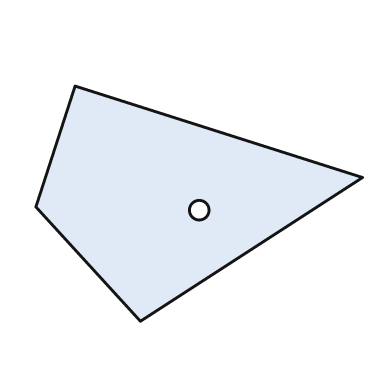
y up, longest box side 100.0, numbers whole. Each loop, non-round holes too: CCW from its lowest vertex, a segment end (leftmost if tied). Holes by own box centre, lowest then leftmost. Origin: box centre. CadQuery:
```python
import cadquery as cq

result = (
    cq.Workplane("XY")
    .moveTo(-18.0, -36.0)
    .lineTo(50.0, 8.0)
    .lineTo(-38.0, 36.0)
    .lineTo(-50.0, -1.0)
    .close()
    .moveTo(0.0, -2.0)
    .circle(3.0)
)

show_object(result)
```